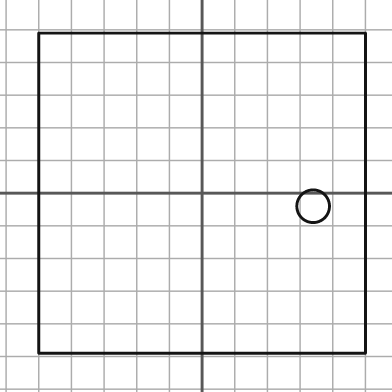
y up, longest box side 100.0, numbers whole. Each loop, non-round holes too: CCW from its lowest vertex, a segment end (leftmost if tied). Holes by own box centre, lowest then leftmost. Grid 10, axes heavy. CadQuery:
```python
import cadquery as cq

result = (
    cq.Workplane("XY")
    .moveTo(-50.0, -49.0)
    .lineTo(50.0, -49.0)
    .lineTo(50.0, 49.0)
    .lineTo(-50.0, 49.0)
    .close()
    .moveTo(34.0, -4.0)
    .circle(5.0)
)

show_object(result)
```